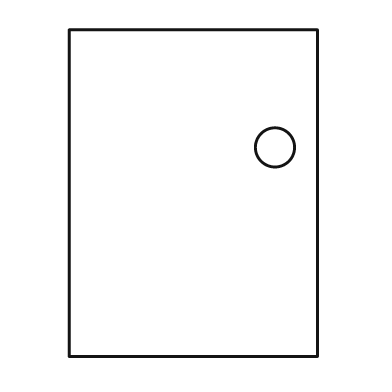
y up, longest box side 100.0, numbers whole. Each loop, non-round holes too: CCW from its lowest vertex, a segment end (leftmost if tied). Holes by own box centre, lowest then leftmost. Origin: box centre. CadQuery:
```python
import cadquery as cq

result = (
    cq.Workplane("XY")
    .moveTo(-38.0, -50.0)
    .lineTo(38.0, -50.0)
    .lineTo(38.0, 50.0)
    .lineTo(-38.0, 50.0)
    .close()
    .moveTo(25.0, 14.0)
    .circle(6.0)
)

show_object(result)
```